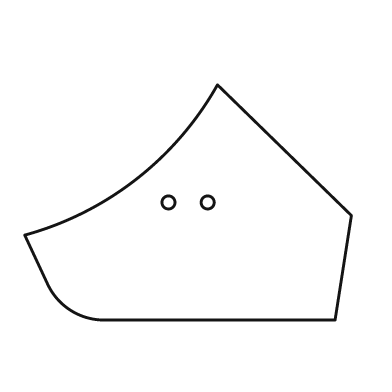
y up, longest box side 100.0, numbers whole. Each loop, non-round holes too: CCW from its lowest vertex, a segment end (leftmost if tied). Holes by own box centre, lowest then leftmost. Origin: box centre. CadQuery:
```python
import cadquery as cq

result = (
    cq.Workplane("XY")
    .moveTo(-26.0, -36.0)
    .lineTo(45.0, -36.0)
    .lineTo(50.0, -4.0)
    .lineTo(9.0, 36.0)
    .threePointArc((-16.0, 7.0), (-50.0, -10.0))
    .lineTo(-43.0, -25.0)
    .threePointArc((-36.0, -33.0), (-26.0, -36.0))
    .close()
    .moveTo(-6.0, 0.0)
    .circle(2.0)
    .moveTo(6.0, 0.0)
    .circle(2.0)
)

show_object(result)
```